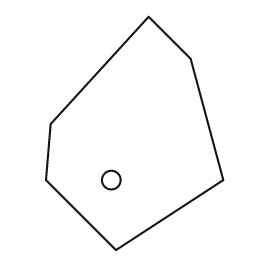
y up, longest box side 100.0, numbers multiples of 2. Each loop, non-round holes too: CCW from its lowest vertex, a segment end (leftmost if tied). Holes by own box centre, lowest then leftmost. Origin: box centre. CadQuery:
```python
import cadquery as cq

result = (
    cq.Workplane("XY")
    .moveTo(-8.0, -50.0)
    .lineTo(38.0, -20.0)
    .lineTo(24.0, 32.0)
    .lineTo(6.0, 50.0)
    .lineTo(-36.0, 4.0)
    .lineTo(-38.0, -20.0)
    .close()
    .moveTo(-10.0, -20.0)
    .circle(4.0)
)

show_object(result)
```